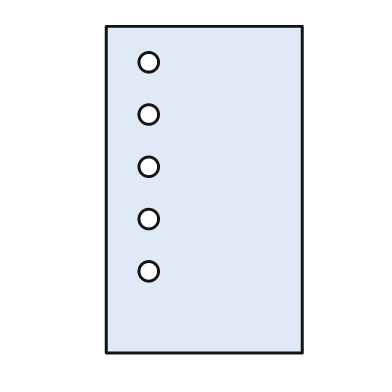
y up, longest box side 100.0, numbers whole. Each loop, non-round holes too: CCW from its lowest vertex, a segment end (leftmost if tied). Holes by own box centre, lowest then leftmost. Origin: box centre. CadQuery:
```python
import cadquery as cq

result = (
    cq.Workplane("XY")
    .moveTo(-30.0, -50.0)
    .lineTo(30.0, -50.0)
    .lineTo(30.0, 50.0)
    .lineTo(-30.0, 50.0)
    .close()
    .moveTo(-17.0, -25.0)
    .circle(3.0)
    .moveTo(-17.0, -9.0)
    .circle(3.0)
    .moveTo(-17.0, 7.0)
    .circle(3.0)
    .moveTo(-17.0, 23.0)
    .circle(3.0)
    .moveTo(-17.0, 39.0)
    .circle(3.0)
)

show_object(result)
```